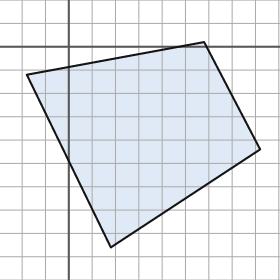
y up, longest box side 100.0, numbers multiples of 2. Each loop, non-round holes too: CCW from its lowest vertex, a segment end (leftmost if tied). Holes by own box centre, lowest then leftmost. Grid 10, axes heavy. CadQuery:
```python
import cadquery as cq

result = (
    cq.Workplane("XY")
    .moveTo(18.0, -86.0)
    .lineTo(82.0, -44.0)
    .lineTo(58.0, 2.0)
    .lineTo(-18.0, -12.0)
    .close()
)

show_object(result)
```